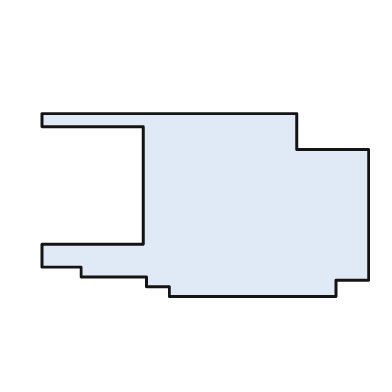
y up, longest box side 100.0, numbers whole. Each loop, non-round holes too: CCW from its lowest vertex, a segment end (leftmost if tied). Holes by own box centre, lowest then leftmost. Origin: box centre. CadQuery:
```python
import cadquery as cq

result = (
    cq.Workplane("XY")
    .moveTo(-11.0, -28.0)
    .lineTo(40.0, -28.0)
    .lineTo(40.0, -23.0)
    .lineTo(50.0, -23.0)
    .lineTo(50.0, 17.0)
    .lineTo(28.0, 17.0)
    .lineTo(28.0, 28.0)
    .lineTo(-50.0, 28.0)
    .lineTo(-50.0, 24.0)
    .lineTo(-19.0, 24.0)
    .lineTo(-19.0, -12.0)
    .lineTo(-50.0, -12.0)
    .lineTo(-50.0, -19.0)
    .lineTo(-38.0, -19.0)
    .lineTo(-38.0, -22.0)
    .lineTo(-18.0, -22.0)
    .lineTo(-18.0, -25.0)
    .lineTo(-11.0, -25.0)
    .close()
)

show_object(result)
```